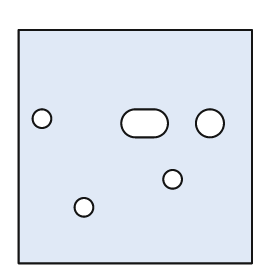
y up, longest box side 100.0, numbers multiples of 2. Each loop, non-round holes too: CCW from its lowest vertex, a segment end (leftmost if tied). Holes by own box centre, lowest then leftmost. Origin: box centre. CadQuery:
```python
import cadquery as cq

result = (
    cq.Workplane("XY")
    .moveTo(-50.0, -50.0)
    .lineTo(50.0, -50.0)
    .lineTo(50.0, 50.0)
    .lineTo(-50.0, 50.0)
    .close()
    .moveTo(-22.0, -26.0)
    .circle(4.0)
    .moveTo(16.0, -14.0)
    .circle(4.0)
    .moveTo(0.0, 4.0)
    .lineTo(8.0, 4.0)
    .threePointArc((14.0, 10.0), (8.0, 16.0))
    .lineTo(0.0, 16.0)
    .threePointArc((-6.0, 10.0), (0.0, 4.0))
    .close()
    .moveTo(32.0, 10.0)
    .circle(6.0)
    .moveTo(-40.0, 12.0)
    .circle(4.0)
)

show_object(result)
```